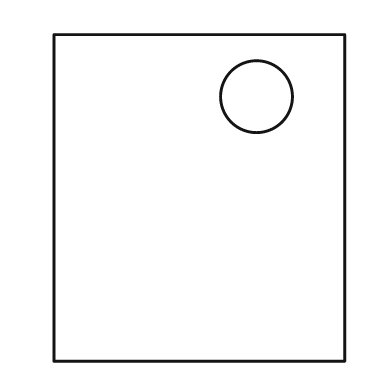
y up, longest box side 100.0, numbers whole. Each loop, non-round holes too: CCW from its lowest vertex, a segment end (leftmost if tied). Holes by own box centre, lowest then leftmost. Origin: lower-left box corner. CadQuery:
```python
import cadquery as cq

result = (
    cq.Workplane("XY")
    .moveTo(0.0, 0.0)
    .lineTo(89.0, 0.0)
    .lineTo(89.0, 100.0)
    .lineTo(0.0, 100.0)
    .close()
    .moveTo(62.0, 81.0)
    .circle(11.0)
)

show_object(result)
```